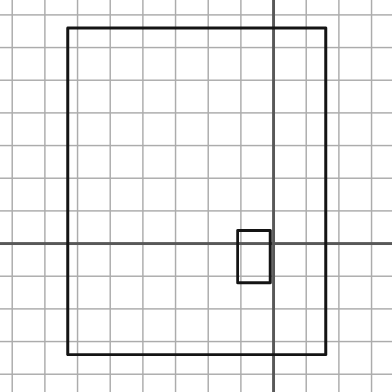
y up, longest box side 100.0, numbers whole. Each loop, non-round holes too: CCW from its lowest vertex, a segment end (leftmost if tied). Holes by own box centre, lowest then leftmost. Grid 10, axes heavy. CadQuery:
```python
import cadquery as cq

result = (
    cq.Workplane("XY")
    .moveTo(-63.0, -34.0)
    .lineTo(16.0, -34.0)
    .lineTo(16.0, 66.0)
    .lineTo(-63.0, 66.0)
    .close()
    .moveTo(-11.0, -12.0)
    .lineTo(-1.0, -12.0)
    .lineTo(-1.0, 4.0)
    .lineTo(-11.0, 4.0)
    .close()
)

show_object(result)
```